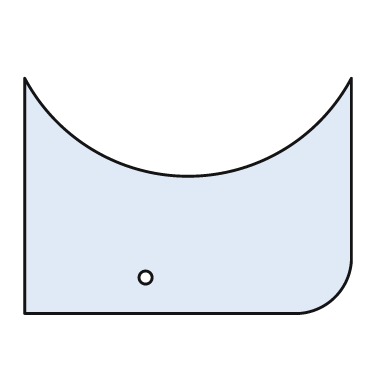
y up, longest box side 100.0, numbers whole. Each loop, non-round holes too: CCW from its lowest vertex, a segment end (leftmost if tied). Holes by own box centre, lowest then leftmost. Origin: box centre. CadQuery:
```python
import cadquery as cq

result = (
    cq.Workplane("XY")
    .moveTo(-50.0, -36.0)
    .lineTo(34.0, -36.0)
    .threePointArc((45.0, -31.0), (50.0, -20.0))
    .lineTo(50.0, 36.0)
    .threePointArc((0.0, 6.0), (-50.0, 36.0))
    .close()
    .moveTo(-13.0, -25.0)
    .circle(2.0)
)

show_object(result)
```